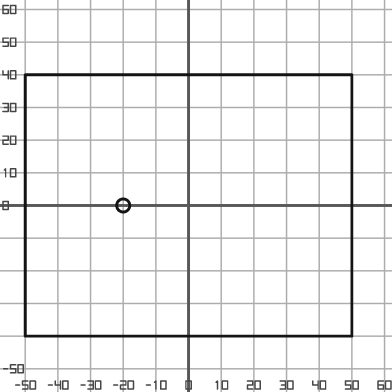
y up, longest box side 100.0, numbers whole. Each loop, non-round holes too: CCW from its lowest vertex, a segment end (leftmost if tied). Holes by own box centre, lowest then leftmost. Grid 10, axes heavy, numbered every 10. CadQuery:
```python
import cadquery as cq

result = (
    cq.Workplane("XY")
    .moveTo(-50.0, -40.0)
    .lineTo(50.0, -40.0)
    .lineTo(50.0, 40.0)
    .lineTo(-50.0, 40.0)
    .close()
    .moveTo(-20.0, 0.0)
    .circle(2.0)
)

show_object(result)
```